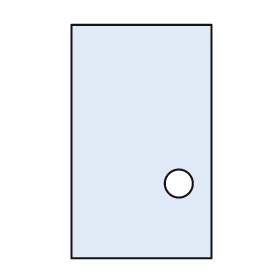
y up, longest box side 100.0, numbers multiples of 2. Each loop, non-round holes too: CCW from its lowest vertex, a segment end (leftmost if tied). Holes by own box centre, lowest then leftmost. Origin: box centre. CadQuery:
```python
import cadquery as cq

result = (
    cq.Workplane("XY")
    .moveTo(-30.0, -50.0)
    .lineTo(30.0, -50.0)
    .lineTo(30.0, 50.0)
    .lineTo(-30.0, 50.0)
    .close()
    .moveTo(16.0, -18.0)
    .circle(6.0)
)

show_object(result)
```